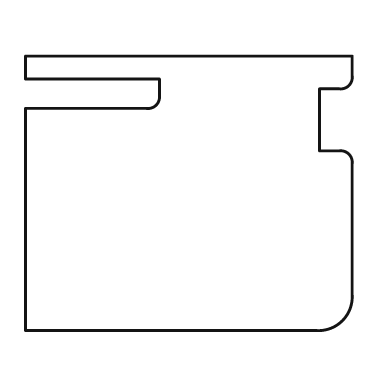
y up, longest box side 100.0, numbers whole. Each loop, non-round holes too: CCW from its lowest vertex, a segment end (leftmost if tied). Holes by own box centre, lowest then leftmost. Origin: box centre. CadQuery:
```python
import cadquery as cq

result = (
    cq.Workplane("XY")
    .moveTo(-50.0, -42.0)
    .lineTo(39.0, -42.0)
    .threePointArc((47.0, -39.0), (50.0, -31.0))
    .lineTo(50.0, 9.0)
    .threePointArc((49.0, 12.0), (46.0, 13.0))
    .lineTo(40.0, 13.0)
    .lineTo(40.0, 32.0)
    .lineTo(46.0, 32.0)
    .threePointArc((49.0, 33.0), (50.0, 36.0))
    .lineTo(50.0, 42.0)
    .lineTo(-50.0, 42.0)
    .lineTo(-50.0, 35.0)
    .lineTo(-9.0, 35.0)
    .lineTo(-9.0, 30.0)
    .threePointArc((-10.0, 27.0), (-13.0, 26.0))
    .lineTo(-50.0, 26.0)
    .close()
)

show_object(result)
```